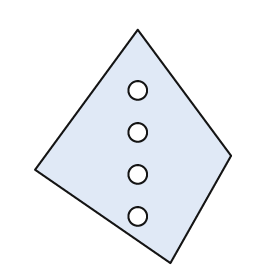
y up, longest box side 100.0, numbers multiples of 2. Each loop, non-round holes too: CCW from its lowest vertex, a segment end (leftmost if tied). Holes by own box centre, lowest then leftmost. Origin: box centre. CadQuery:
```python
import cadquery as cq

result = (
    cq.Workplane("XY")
    .moveTo(16.0, -50.0)
    .lineTo(42.0, -4.0)
    .lineTo(2.0, 50.0)
    .lineTo(-42.0, -10.0)
    .close()
    .moveTo(2.0, -30.0)
    .circle(4.0)
    .moveTo(2.0, -12.0)
    .circle(4.0)
    .moveTo(2.0, 6.0)
    .circle(4.0)
    .moveTo(2.0, 24.0)
    .circle(4.0)
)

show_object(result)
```